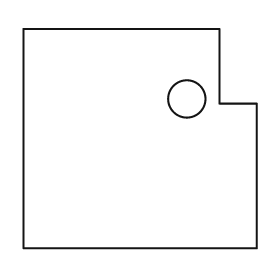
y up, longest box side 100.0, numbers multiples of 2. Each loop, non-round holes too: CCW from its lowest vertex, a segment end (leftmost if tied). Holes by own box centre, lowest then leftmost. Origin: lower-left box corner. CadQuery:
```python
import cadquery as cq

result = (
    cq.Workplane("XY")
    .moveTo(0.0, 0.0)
    .lineTo(100.0, 0.0)
    .lineTo(100.0, 62.0)
    .lineTo(84.0, 62.0)
    .lineTo(84.0, 94.0)
    .lineTo(0.0, 94.0)
    .close()
    .moveTo(70.0, 64.0)
    .circle(8.0)
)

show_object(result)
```